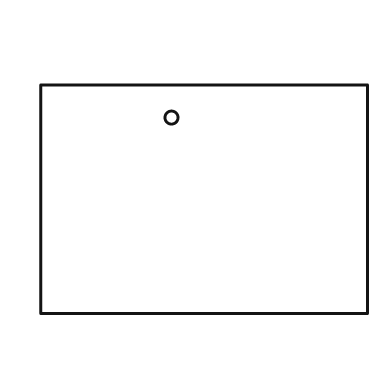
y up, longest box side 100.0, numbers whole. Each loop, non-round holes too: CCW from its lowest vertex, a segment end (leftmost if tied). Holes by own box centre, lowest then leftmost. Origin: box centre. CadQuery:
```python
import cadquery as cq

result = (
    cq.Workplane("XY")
    .moveTo(-50.0, -35.0)
    .lineTo(50.0, -35.0)
    .lineTo(50.0, 35.0)
    .lineTo(-50.0, 35.0)
    .close()
    .moveTo(-10.0, 25.0)
    .circle(2.0)
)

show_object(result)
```